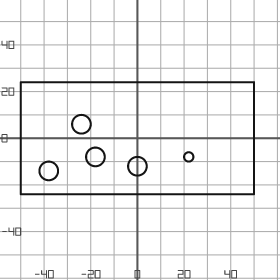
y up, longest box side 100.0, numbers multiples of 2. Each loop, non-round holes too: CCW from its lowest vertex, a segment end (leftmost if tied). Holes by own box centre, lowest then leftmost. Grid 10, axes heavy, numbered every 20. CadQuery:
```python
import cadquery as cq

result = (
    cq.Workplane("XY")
    .moveTo(-50.0, -24.0)
    .lineTo(50.0, -24.0)
    .lineTo(50.0, 24.0)
    .lineTo(-50.0, 24.0)
    .close()
    .moveTo(-38.0, -14.0)
    .circle(4.0)
    .moveTo(0.0, -12.0)
    .circle(4.0)
    .moveTo(-18.0, -8.0)
    .circle(4.0)
    .moveTo(22.0, -8.0)
    .circle(2.0)
    .moveTo(-24.0, 6.0)
    .circle(4.0)
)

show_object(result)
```